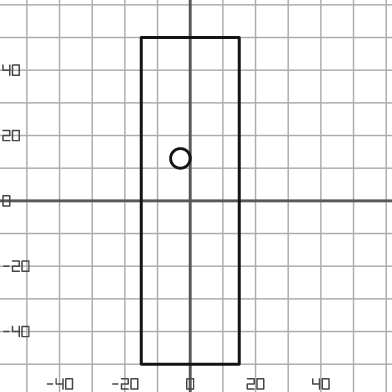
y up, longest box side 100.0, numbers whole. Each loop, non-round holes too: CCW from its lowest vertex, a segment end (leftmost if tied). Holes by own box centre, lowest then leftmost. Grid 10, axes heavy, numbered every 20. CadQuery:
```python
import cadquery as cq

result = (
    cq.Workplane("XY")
    .moveTo(-15.0, -50.0)
    .lineTo(15.0, -50.0)
    .lineTo(15.0, 50.0)
    .lineTo(-15.0, 50.0)
    .close()
    .moveTo(-3.0, 13.0)
    .circle(3.0)
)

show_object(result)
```